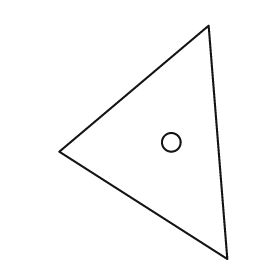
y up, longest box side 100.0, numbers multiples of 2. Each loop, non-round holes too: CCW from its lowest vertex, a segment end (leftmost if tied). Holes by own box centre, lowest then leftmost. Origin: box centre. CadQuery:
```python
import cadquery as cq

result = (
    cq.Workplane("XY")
    .moveTo(36.0, -50.0)
    .lineTo(28.0, 50.0)
    .lineTo(-36.0, -4.0)
    .close()
    .moveTo(12.0, 0.0)
    .circle(4.0)
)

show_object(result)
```